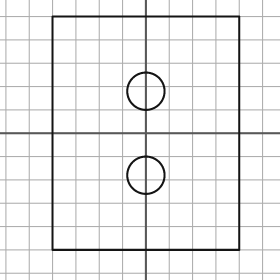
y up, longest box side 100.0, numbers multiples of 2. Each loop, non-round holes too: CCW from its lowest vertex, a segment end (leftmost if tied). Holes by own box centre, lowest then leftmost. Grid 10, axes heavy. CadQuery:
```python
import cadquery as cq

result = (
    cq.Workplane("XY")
    .moveTo(-40.0, -50.0)
    .lineTo(40.0, -50.0)
    .lineTo(40.0, 50.0)
    .lineTo(-40.0, 50.0)
    .close()
    .moveTo(0.0, -18.0)
    .circle(8.0)
    .moveTo(0.0, 18.0)
    .circle(8.0)
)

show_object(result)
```